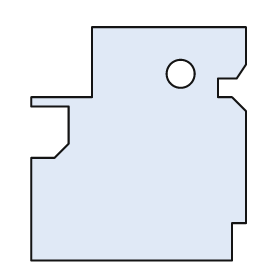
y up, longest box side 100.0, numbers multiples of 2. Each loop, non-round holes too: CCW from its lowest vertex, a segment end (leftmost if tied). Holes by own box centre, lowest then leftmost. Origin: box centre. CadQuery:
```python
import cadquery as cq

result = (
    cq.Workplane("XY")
    .moveTo(-46.0, -50.0)
    .lineTo(40.0, -50.0)
    .lineTo(40.0, -34.0)
    .lineTo(46.0, -34.0)
    .lineTo(46.0, 14.0)
    .lineTo(40.0, 20.0)
    .lineTo(34.0, 20.0)
    .lineTo(34.0, 28.0)
    .lineTo(42.0, 28.0)
    .lineTo(46.0, 34.0)
    .lineTo(46.0, 50.0)
    .lineTo(-20.0, 50.0)
    .lineTo(-20.0, 20.0)
    .lineTo(-46.0, 20.0)
    .lineTo(-46.0, 16.0)
    .lineTo(-30.0, 16.0)
    .lineTo(-30.0, 0.0)
    .lineTo(-36.0, -6.0)
    .lineTo(-46.0, -6.0)
    .close()
    .moveTo(18.0, 30.0)
    .circle(6.0)
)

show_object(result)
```